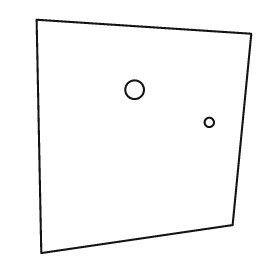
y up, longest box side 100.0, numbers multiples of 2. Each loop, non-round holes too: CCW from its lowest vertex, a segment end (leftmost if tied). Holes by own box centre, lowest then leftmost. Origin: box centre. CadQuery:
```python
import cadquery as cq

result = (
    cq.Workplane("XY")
    .moveTo(-44.0, -50.0)
    .lineTo(38.0, -38.0)
    .lineTo(46.0, 44.0)
    .lineTo(-46.0, 50.0)
    .close()
    .moveTo(28.0, 6.0)
    .circle(2.0)
    .moveTo(-4.0, 20.0)
    .circle(4.0)
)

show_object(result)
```